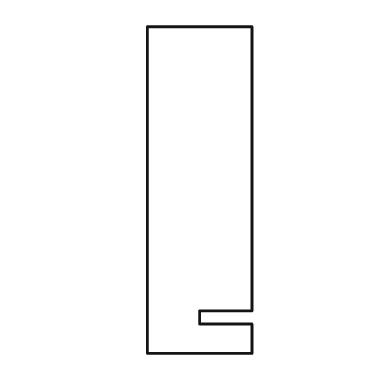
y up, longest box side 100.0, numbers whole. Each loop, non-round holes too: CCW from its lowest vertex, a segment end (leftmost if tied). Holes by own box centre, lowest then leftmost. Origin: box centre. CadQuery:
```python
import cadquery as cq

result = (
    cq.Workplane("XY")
    .moveTo(-16.0, -50.0)
    .lineTo(16.0, -50.0)
    .lineTo(16.0, -41.0)
    .lineTo(0.0, -41.0)
    .lineTo(0.0, -37.0)
    .lineTo(16.0, -37.0)
    .lineTo(16.0, 50.0)
    .lineTo(-16.0, 50.0)
    .close()
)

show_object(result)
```